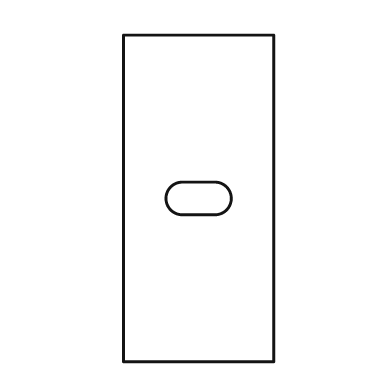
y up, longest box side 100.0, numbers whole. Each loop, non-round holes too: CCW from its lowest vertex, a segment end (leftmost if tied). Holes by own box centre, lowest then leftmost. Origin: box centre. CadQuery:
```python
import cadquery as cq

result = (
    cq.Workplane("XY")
    .moveTo(-23.0, -50.0)
    .lineTo(23.0, -50.0)
    .lineTo(23.0, 50.0)
    .lineTo(-23.0, 50.0)
    .close()
    .moveTo(-5.0, -5.0)
    .lineTo(5.0, -5.0)
    .threePointArc((10.0, 0.0), (5.0, 5.0))
    .lineTo(-5.0, 5.0)
    .threePointArc((-10.0, 0.0), (-5.0, -5.0))
    .close()
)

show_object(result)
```